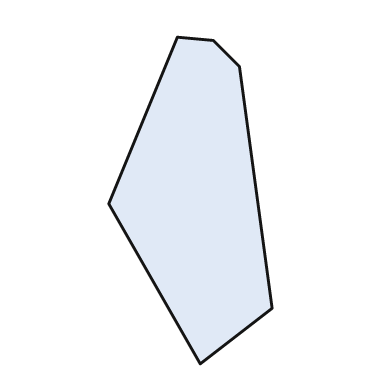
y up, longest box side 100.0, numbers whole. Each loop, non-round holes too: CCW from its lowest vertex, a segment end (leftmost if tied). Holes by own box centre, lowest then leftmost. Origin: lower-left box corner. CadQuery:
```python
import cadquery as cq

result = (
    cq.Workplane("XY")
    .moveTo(28.0, 0.0)
    .lineTo(50.0, 17.0)
    .lineTo(40.0, 91.0)
    .lineTo(32.0, 99.0)
    .lineTo(21.0, 100.0)
    .lineTo(0.0, 49.0)
    .close()
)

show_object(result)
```